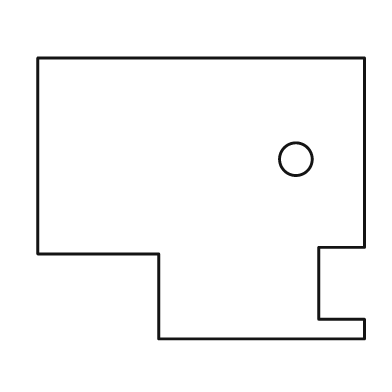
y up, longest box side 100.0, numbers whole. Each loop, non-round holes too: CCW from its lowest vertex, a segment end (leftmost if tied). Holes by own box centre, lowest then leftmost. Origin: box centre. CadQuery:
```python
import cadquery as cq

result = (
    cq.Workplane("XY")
    .moveTo(-13.0, -43.0)
    .lineTo(50.0, -43.0)
    .lineTo(50.0, -37.0)
    .lineTo(36.0, -37.0)
    .lineTo(36.0, -15.0)
    .lineTo(50.0, -15.0)
    .lineTo(50.0, 43.0)
    .lineTo(-50.0, 43.0)
    .lineTo(-50.0, -17.0)
    .lineTo(-13.0, -17.0)
    .close()
    .moveTo(29.0, 12.0)
    .circle(5.0)
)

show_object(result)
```